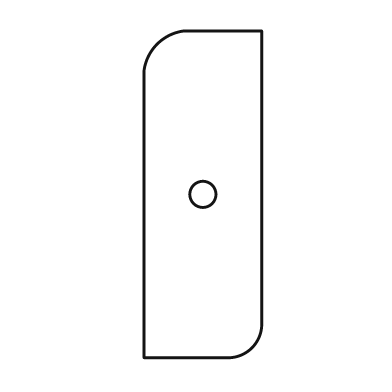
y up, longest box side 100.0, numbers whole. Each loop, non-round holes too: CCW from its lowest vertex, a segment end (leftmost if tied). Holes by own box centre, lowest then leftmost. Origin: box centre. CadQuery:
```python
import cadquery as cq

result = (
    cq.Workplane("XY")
    .moveTo(-18.0, -50.0)
    .lineTo(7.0, -50.0)
    .threePointArc((15.0, -47.0), (18.0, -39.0))
    .lineTo(18.0, 50.0)
    .lineTo(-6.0, 50.0)
    .threePointArc((-14.0, 46.0), (-18.0, 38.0))
    .close()
    .moveTo(0.0, 0.0)
    .circle(4.0)
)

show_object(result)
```